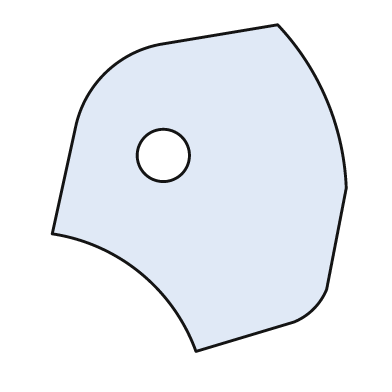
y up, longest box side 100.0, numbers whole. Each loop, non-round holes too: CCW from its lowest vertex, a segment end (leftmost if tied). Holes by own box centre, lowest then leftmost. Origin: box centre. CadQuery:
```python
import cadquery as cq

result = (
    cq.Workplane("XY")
    .moveTo(-1.0, -50.0)
    .lineTo(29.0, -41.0)
    .threePointArc((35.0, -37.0), (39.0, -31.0))
    .lineTo(45.0, 0.0)
    .threePointArc((39.0, 27.0), (24.0, 50.0))
    .lineTo(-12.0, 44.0)
    .threePointArc((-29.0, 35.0), (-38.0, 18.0))
    .lineTo(-45.0, -14.0)
    .threePointArc((-18.0, -26.0), (-1.0, -50.0))
    .close()
    .moveTo(-11.0, 10.0)
    .circle(8.0)
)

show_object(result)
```